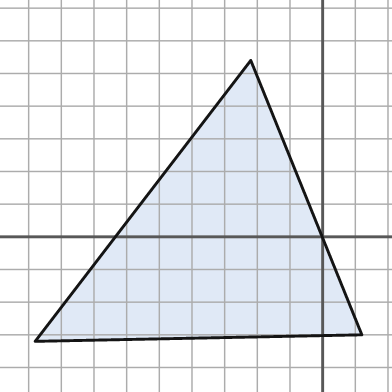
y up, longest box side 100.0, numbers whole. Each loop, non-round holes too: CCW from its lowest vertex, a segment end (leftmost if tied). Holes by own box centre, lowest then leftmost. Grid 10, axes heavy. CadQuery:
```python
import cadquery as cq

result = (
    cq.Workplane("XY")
    .moveTo(-88.0, -32.0)
    .lineTo(12.0, -30.0)
    .lineTo(-22.0, 54.0)
    .close()
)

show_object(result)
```